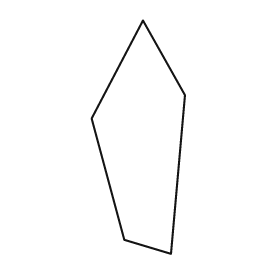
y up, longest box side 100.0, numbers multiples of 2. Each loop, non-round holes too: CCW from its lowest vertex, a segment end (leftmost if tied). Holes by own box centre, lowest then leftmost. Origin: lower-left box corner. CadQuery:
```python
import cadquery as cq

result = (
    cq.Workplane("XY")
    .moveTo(34.0, 0.0)
    .lineTo(40.0, 68.0)
    .lineTo(22.0, 100.0)
    .lineTo(0.0, 58.0)
    .lineTo(14.0, 6.0)
    .close()
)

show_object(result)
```